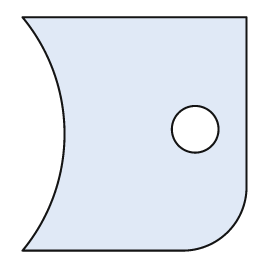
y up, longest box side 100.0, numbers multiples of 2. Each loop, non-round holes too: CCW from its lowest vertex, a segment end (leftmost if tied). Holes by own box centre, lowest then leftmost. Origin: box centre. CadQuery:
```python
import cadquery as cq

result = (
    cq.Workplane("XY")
    .moveTo(-48.0, -50.0)
    .lineTo(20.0, -50.0)
    .threePointArc((40.0, -42.0), (48.0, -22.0))
    .lineTo(48.0, 50.0)
    .lineTo(-48.0, 50.0)
    .threePointArc((-30.0, 0.0), (-48.0, -50.0))
    .close()
    .moveTo(26.0, 2.0)
    .circle(10.0)
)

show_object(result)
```